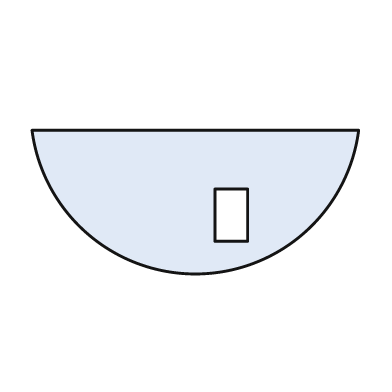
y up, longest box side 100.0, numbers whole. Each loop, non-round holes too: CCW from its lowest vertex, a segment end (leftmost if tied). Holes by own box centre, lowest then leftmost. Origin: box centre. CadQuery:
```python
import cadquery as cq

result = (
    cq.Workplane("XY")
    .moveTo(-50.0, 22.0)
    .threePointArc((0.0, -22.0), (50.0, 22.0))
    .close()
    .moveTo(6.0, -12.0)
    .lineTo(16.0, -12.0)
    .lineTo(16.0, 4.0)
    .lineTo(6.0, 4.0)
    .close()
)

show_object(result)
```